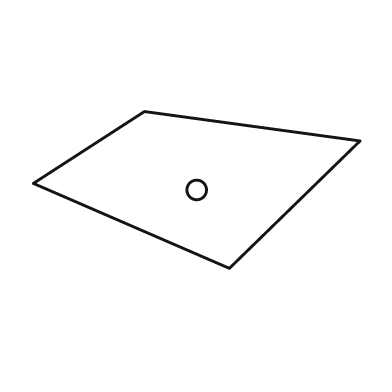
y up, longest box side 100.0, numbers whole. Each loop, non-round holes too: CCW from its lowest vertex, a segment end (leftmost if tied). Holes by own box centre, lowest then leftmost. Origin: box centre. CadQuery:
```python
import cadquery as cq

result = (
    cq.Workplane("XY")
    .moveTo(10.0, -24.0)
    .lineTo(50.0, 15.0)
    .lineTo(-16.0, 24.0)
    .lineTo(-50.0, 2.0)
    .close()
    .moveTo(0.0, 0.0)
    .circle(3.0)
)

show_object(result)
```